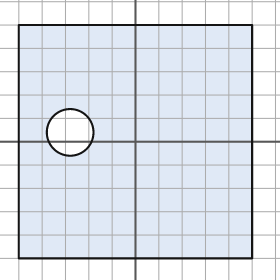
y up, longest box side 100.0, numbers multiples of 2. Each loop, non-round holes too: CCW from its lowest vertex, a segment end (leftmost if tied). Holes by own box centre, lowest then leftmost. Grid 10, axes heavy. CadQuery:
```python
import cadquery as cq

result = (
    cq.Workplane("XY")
    .moveTo(-50.0, -50.0)
    .lineTo(50.0, -50.0)
    .lineTo(50.0, 50.0)
    .lineTo(-50.0, 50.0)
    .close()
    .moveTo(-28.0, 4.0)
    .circle(10.0)
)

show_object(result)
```